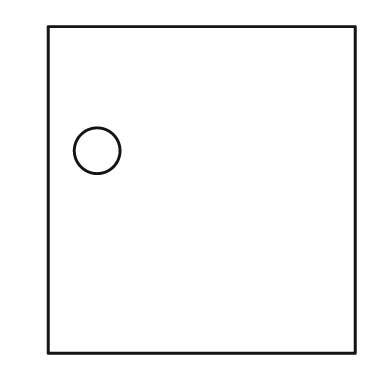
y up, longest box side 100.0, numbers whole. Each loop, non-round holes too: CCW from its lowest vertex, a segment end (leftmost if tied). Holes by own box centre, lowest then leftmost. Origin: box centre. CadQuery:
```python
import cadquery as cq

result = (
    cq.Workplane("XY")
    .moveTo(-47.0, -50.0)
    .lineTo(47.0, -50.0)
    .lineTo(47.0, 50.0)
    .lineTo(-47.0, 50.0)
    .close()
    .moveTo(-32.0, 12.0)
    .circle(7.0)
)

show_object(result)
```